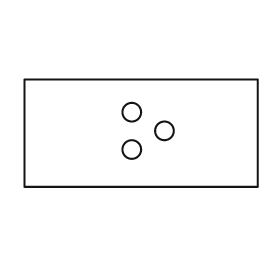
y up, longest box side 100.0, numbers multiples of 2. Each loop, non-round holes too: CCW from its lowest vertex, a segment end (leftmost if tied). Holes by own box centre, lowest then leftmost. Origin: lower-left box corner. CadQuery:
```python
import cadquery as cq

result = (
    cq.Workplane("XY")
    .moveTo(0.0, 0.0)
    .lineTo(100.0, 0.0)
    .lineTo(100.0, 46.0)
    .lineTo(0.0, 46.0)
    .close()
    .moveTo(46.0, 16.0)
    .circle(4.0)
    .moveTo(60.0, 24.0)
    .circle(4.0)
    .moveTo(46.0, 32.0)
    .circle(4.0)
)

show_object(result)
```